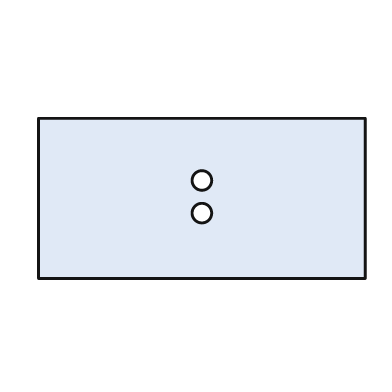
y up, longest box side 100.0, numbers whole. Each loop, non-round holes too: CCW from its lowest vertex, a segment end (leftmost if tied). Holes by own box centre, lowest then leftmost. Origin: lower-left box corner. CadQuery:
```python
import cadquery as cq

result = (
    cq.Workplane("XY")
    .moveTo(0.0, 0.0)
    .lineTo(100.0, 0.0)
    .lineTo(100.0, 49.0)
    .lineTo(0.0, 49.0)
    .close()
    .moveTo(50.0, 20.0)
    .circle(3.0)
    .moveTo(50.0, 30.0)
    .circle(3.0)
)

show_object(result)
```